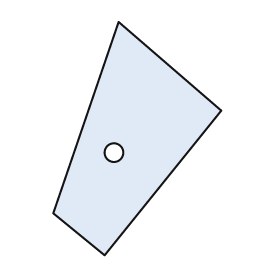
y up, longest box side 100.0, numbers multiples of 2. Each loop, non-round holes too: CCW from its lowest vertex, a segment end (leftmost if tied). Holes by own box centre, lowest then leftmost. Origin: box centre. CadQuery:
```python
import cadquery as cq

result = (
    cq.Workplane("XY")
    .moveTo(-14.0, -50.0)
    .lineTo(36.0, 12.0)
    .lineTo(-8.0, 50.0)
    .lineTo(-36.0, -32.0)
    .close()
    .moveTo(-10.0, -6.0)
    .circle(4.0)
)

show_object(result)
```